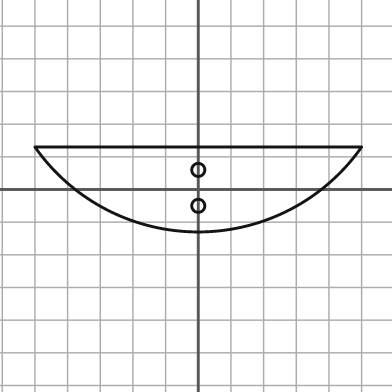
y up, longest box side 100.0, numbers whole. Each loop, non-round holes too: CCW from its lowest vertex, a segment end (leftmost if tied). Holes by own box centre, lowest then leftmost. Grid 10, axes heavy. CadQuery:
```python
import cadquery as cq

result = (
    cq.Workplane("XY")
    .moveTo(-50.0, 13.0)
    .threePointArc((0.0, -13.0), (50.0, 13.0))
    .close()
    .moveTo(0.0, -5.0)
    .circle(2.0)
    .moveTo(0.0, 6.0)
    .circle(2.0)
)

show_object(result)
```